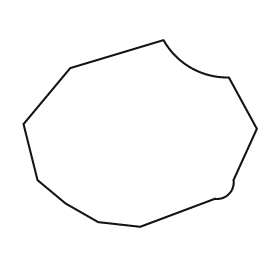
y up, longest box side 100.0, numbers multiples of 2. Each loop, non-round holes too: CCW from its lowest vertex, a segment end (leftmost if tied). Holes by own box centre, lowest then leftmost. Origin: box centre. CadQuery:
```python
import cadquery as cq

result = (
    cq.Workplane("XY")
    .moveTo(0.0, -40.0)
    .lineTo(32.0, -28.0)
    .threePointArc((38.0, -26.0), (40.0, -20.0))
    .lineTo(50.0, 2.0)
    .lineTo(38.0, 24.0)
    .threePointArc((22.0, 28.0), (10.0, 40.0))
    .lineTo(-30.0, 28.0)
    .lineTo(-50.0, 4.0)
    .lineTo(-44.0, -20.0)
    .lineTo(-32.0, -30.0)
    .lineTo(-18.0, -38.0)
    .close()
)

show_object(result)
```